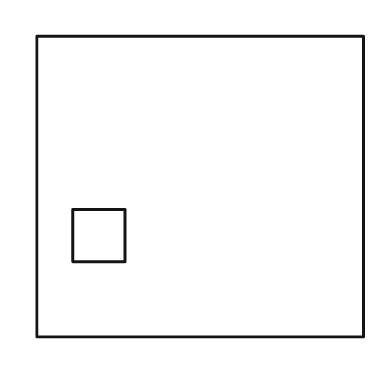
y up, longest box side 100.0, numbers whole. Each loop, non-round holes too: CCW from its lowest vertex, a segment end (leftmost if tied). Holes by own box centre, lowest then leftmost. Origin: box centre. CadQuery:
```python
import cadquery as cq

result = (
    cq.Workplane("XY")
    .moveTo(-50.0, -46.0)
    .lineTo(50.0, -46.0)
    .lineTo(50.0, 46.0)
    .lineTo(-50.0, 46.0)
    .close()
    .moveTo(-39.0, -23.0)
    .lineTo(-23.0, -23.0)
    .lineTo(-23.0, -7.0)
    .lineTo(-39.0, -7.0)
    .close()
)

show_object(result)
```